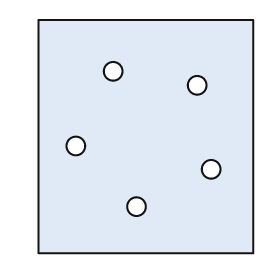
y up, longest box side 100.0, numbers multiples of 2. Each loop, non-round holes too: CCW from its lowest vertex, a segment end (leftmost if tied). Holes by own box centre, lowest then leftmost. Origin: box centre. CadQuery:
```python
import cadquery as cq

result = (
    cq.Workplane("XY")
    .moveTo(-46.0, -50.0)
    .lineTo(46.0, -50.0)
    .lineTo(46.0, 50.0)
    .lineTo(-46.0, 50.0)
    .close()
    .moveTo(-4.0, -30.0)
    .circle(4.0)
    .moveTo(28.0, -14.0)
    .circle(4.0)
    .moveTo(-30.0, -4.0)
    .circle(4.0)
    .moveTo(22.0, 22.0)
    .circle(4.0)
    .moveTo(-14.0, 28.0)
    .circle(4.0)
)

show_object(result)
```